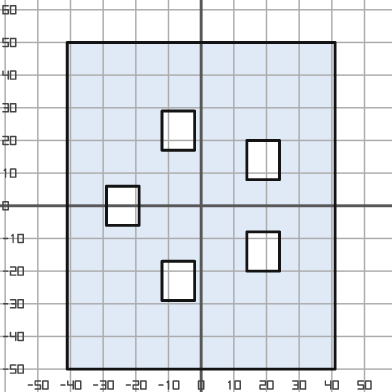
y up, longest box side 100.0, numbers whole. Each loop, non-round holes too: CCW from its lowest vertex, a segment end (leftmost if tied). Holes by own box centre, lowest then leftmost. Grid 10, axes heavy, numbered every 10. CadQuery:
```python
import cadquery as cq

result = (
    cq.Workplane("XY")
    .moveTo(-41.0, -50.0)
    .lineTo(41.0, -50.0)
    .lineTo(41.0, 50.0)
    .lineTo(-41.0, 50.0)
    .close()
    .moveTo(-12.0, -29.0)
    .lineTo(-2.0, -29.0)
    .lineTo(-2.0, -17.0)
    .lineTo(-12.0, -17.0)
    .close()
    .moveTo(14.0, -20.0)
    .lineTo(24.0, -20.0)
    .lineTo(24.0, -8.0)
    .lineTo(14.0, -8.0)
    .close()
    .moveTo(-29.0, -6.0)
    .lineTo(-19.0, -6.0)
    .lineTo(-19.0, 6.0)
    .lineTo(-29.0, 6.0)
    .close()
    .moveTo(14.0, 8.0)
    .lineTo(24.0, 8.0)
    .lineTo(24.0, 20.0)
    .lineTo(14.0, 20.0)
    .close()
    .moveTo(-12.0, 17.0)
    .lineTo(-2.0, 17.0)
    .lineTo(-2.0, 29.0)
    .lineTo(-12.0, 29.0)
    .close()
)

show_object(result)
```